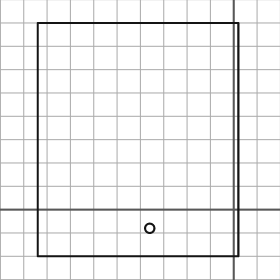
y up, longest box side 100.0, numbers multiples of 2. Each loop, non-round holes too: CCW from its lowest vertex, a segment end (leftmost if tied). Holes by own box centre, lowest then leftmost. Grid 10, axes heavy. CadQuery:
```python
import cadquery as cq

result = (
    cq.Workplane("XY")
    .moveTo(-84.0, -20.0)
    .lineTo(2.0, -20.0)
    .lineTo(2.0, 80.0)
    .lineTo(-84.0, 80.0)
    .close()
    .moveTo(-36.0, -8.0)
    .circle(2.0)
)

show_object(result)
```